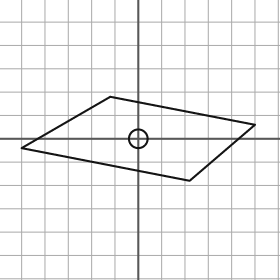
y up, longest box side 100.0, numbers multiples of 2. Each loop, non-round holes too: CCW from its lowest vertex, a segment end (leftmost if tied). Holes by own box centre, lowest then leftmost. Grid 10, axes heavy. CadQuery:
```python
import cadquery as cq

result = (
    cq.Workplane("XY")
    .moveTo(22.0, -18.0)
    .lineTo(50.0, 6.0)
    .lineTo(-12.0, 18.0)
    .lineTo(-50.0, -4.0)
    .close()
    .moveTo(0.0, 0.0)
    .circle(4.0)
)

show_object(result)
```